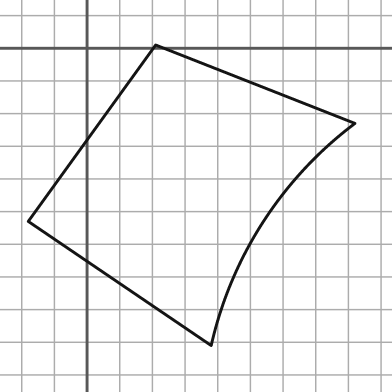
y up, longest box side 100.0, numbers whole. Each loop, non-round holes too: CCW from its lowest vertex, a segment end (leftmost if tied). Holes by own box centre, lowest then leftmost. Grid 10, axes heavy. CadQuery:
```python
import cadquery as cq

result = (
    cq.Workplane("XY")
    .moveTo(38.0, -91.0)
    .threePointArc((54.0, -53.0), (82.0, -23.0))
    .lineTo(21.0, 1.0)
    .lineTo(-18.0, -53.0)
    .close()
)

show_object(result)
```